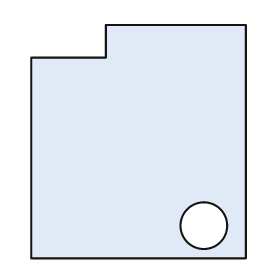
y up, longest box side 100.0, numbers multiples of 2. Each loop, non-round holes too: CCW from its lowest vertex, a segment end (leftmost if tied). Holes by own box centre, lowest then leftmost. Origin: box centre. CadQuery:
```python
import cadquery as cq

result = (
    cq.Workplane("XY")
    .moveTo(-46.0, -50.0)
    .lineTo(46.0, -50.0)
    .lineTo(46.0, 50.0)
    .lineTo(-14.0, 50.0)
    .lineTo(-14.0, 36.0)
    .lineTo(-46.0, 36.0)
    .close()
    .moveTo(28.0, -36.0)
    .circle(10.0)
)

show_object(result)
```